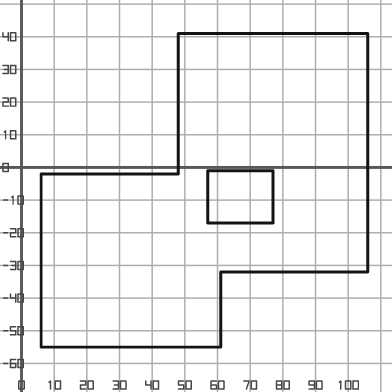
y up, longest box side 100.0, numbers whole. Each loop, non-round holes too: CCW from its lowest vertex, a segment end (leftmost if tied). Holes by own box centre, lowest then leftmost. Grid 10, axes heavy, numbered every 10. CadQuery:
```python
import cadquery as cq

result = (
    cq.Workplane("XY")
    .moveTo(6.0, -55.0)
    .lineTo(61.0, -55.0)
    .lineTo(61.0, -32.0)
    .lineTo(106.0, -32.0)
    .lineTo(106.0, 41.0)
    .lineTo(48.0, 41.0)
    .lineTo(48.0, -2.0)
    .lineTo(6.0, -2.0)
    .close()
    .moveTo(57.0, -17.0)
    .lineTo(77.0, -17.0)
    .lineTo(77.0, -1.0)
    .lineTo(57.0, -1.0)
    .close()
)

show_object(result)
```